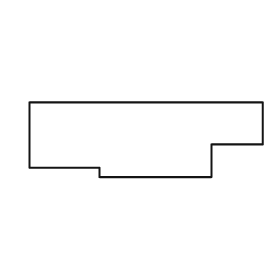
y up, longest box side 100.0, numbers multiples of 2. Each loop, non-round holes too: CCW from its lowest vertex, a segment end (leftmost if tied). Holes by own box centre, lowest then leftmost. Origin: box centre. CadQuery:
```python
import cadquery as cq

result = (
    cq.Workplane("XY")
    .moveTo(-20.0, -16.0)
    .lineTo(28.0, -16.0)
    .lineTo(28.0, -2.0)
    .lineTo(50.0, -2.0)
    .lineTo(50.0, 16.0)
    .lineTo(-50.0, 16.0)
    .lineTo(-50.0, -12.0)
    .lineTo(-20.0, -12.0)
    .close()
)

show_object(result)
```